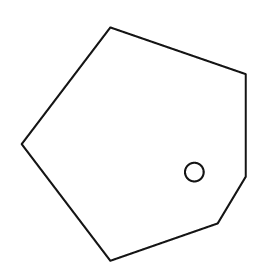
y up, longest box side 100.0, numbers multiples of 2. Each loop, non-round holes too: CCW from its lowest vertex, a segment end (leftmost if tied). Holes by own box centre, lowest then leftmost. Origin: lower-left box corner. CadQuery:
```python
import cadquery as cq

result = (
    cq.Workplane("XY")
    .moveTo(38.0, 0.0)
    .lineTo(84.0, 16.0)
    .lineTo(96.0, 36.0)
    .lineTo(96.0, 80.0)
    .lineTo(38.0, 100.0)
    .lineTo(0.0, 50.0)
    .close()
    .moveTo(74.0, 38.0)
    .circle(4.0)
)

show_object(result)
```